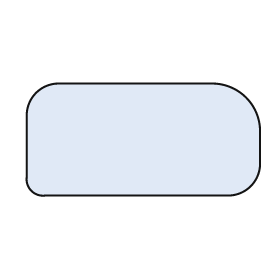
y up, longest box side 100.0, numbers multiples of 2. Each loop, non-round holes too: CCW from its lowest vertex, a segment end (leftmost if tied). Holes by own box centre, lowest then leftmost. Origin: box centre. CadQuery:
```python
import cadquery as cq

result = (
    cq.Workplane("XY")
    .moveTo(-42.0, -24.0)
    .lineTo(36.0, -24.0)
    .threePointArc((46.0, -20.0), (50.0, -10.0))
    .lineTo(50.0, 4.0)
    .threePointArc((44.0, 18.0), (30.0, 24.0))
    .lineTo(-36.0, 24.0)
    .threePointArc((-46.0, 20.0), (-50.0, 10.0))
    .lineTo(-50.0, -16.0)
    .threePointArc((-48.0, -22.0), (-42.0, -24.0))
    .close()
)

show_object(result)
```